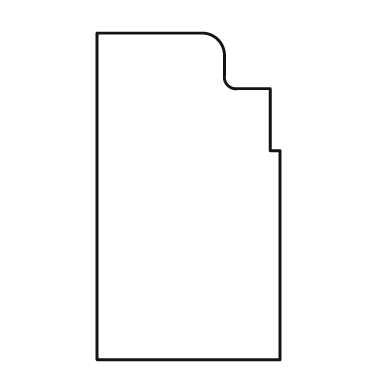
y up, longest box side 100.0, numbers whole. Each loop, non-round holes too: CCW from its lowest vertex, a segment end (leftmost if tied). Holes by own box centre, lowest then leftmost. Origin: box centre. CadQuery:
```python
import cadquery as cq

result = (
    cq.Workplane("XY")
    .moveTo(-28.0, -50.0)
    .lineTo(28.0, -50.0)
    .lineTo(28.0, 14.0)
    .lineTo(25.0, 14.0)
    .lineTo(25.0, 33.0)
    .lineTo(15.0, 33.0)
    .threePointArc((12.0, 34.0), (11.0, 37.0))
    .lineTo(11.0, 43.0)
    .threePointArc((9.0, 48.0), (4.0, 50.0))
    .lineTo(-28.0, 50.0)
    .close()
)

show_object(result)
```